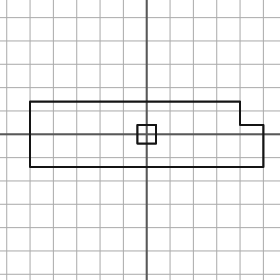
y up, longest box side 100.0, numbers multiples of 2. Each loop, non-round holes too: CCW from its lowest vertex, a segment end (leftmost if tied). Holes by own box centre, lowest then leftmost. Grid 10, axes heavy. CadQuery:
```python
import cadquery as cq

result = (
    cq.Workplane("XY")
    .moveTo(-50.0, -14.0)
    .lineTo(50.0, -14.0)
    .lineTo(50.0, 4.0)
    .lineTo(40.0, 4.0)
    .lineTo(40.0, 14.0)
    .lineTo(-50.0, 14.0)
    .close()
    .moveTo(-4.0, -4.0)
    .lineTo(4.0, -4.0)
    .lineTo(4.0, 4.0)
    .lineTo(-4.0, 4.0)
    .close()
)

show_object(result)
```